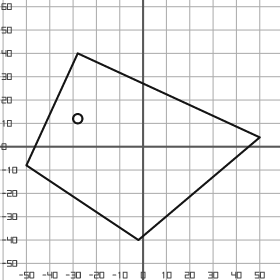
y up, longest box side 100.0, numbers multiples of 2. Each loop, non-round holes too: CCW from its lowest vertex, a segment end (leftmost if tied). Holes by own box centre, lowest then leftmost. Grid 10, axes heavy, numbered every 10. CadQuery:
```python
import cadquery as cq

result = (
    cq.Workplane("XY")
    .moveTo(-2.0, -40.0)
    .lineTo(50.0, 4.0)
    .lineTo(-28.0, 40.0)
    .lineTo(-50.0, -8.0)
    .close()
    .moveTo(-28.0, 12.0)
    .circle(2.0)
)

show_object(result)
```